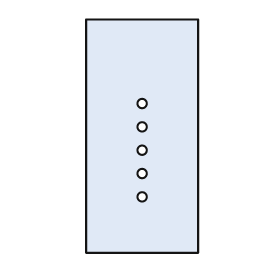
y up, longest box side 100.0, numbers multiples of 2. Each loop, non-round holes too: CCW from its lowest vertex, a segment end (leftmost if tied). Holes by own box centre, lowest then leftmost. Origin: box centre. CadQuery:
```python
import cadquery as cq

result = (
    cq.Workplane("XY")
    .moveTo(-24.0, -50.0)
    .lineTo(24.0, -50.0)
    .lineTo(24.0, 50.0)
    .lineTo(-24.0, 50.0)
    .close()
    .moveTo(0.0, -26.0)
    .circle(2.0)
    .moveTo(0.0, -16.0)
    .circle(2.0)
    .moveTo(0.0, -6.0)
    .circle(2.0)
    .moveTo(0.0, 4.0)
    .circle(2.0)
    .moveTo(0.0, 14.0)
    .circle(2.0)
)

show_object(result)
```